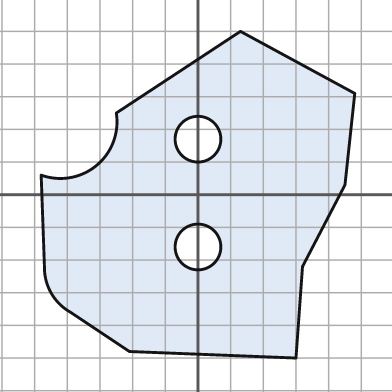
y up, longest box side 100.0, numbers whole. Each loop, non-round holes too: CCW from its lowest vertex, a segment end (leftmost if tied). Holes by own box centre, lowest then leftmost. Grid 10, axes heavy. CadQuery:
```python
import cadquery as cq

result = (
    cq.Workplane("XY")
    .moveTo(30.0, -50.0)
    .lineTo(32.0, -22.0)
    .lineTo(45.0, 3.0)
    .lineTo(48.0, 31.0)
    .lineTo(13.0, 50.0)
    .lineTo(-25.0, 25.0)
    .threePointArc((-31.0, 9.0), (-48.0, 6.0))
    .lineTo(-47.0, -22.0)
    .threePointArc((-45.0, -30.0), (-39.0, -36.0))
    .lineTo(-21.0, -48.0)
    .close()
    .moveTo(0.0, -16.0)
    .circle(7.0)
    .moveTo(0.0, 17.0)
    .circle(7.0)
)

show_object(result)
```